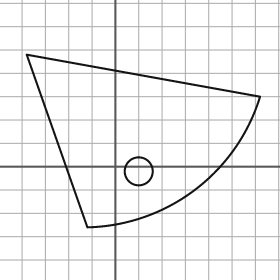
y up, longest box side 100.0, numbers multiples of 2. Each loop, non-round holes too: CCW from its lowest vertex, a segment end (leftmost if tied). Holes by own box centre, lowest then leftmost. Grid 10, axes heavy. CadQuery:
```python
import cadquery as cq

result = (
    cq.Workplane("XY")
    .moveTo(-12.0, -26.0)
    .threePointArc((34.0, -10.0), (62.0, 30.0))
    .lineTo(-38.0, 48.0)
    .close()
    .moveTo(10.0, -2.0)
    .circle(6.0)
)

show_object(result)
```